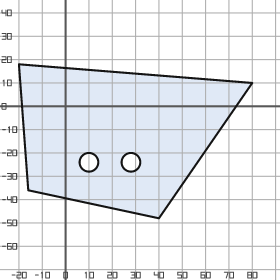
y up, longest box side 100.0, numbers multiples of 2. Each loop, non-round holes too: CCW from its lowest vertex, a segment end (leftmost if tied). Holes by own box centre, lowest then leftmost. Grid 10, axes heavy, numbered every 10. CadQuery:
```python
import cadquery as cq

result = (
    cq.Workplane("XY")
    .moveTo(40.0, -48.0)
    .lineTo(80.0, 10.0)
    .lineTo(-20.0, 18.0)
    .lineTo(-16.0, -36.0)
    .close()
    .moveTo(10.0, -24.0)
    .circle(4.0)
    .moveTo(28.0, -24.0)
    .circle(4.0)
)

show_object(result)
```